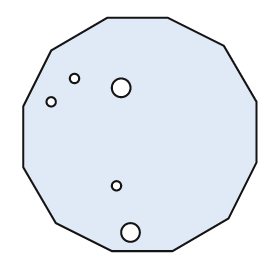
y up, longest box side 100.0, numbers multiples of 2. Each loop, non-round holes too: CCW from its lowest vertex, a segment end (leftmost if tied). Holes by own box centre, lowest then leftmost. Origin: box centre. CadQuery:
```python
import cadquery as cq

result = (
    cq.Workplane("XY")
    .moveTo(-12.0, -50.0)
    .lineTo(14.0, -50.0)
    .lineTo(38.0, -36.0)
    .lineTo(50.0, -12.0)
    .lineTo(50.0, 14.0)
    .lineTo(36.0, 38.0)
    .lineTo(12.0, 50.0)
    .lineTo(-14.0, 50.0)
    .lineTo(-38.0, 36.0)
    .lineTo(-50.0, 12.0)
    .lineTo(-50.0, -14.0)
    .lineTo(-36.0, -38.0)
    .close()
    .moveTo(-4.0, -42.0)
    .circle(4.0)
    .moveTo(-10.0, -22.0)
    .circle(2.0)
    .moveTo(-38.0, 14.0)
    .circle(2.0)
    .moveTo(-8.0, 20.0)
    .circle(4.0)
    .moveTo(-28.0, 24.0)
    .circle(2.0)
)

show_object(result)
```